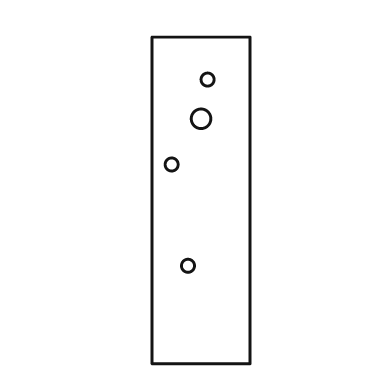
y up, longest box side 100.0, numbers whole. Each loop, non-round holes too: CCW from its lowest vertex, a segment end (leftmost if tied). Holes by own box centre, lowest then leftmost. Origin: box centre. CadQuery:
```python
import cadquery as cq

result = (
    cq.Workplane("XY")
    .moveTo(-15.0, -50.0)
    .lineTo(15.0, -50.0)
    .lineTo(15.0, 50.0)
    .lineTo(-15.0, 50.0)
    .close()
    .moveTo(-4.0, -20.0)
    .circle(2.0)
    .moveTo(-9.0, 11.0)
    .circle(2.0)
    .moveTo(0.0, 25.0)
    .circle(3.0)
    .moveTo(2.0, 37.0)
    .circle(2.0)
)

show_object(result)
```